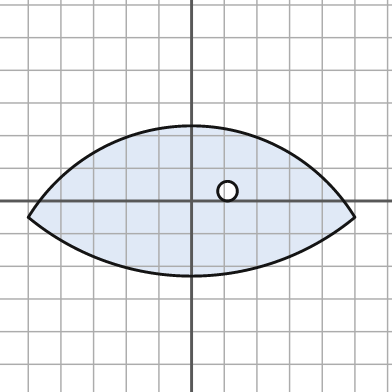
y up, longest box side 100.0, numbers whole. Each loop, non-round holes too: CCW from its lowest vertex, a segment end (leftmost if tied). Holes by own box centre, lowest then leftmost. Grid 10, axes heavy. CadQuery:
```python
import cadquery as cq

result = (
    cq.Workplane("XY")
    .moveTo(-50.0, -5.0)
    .threePointArc((0.0, -23.0), (50.0, -5.0))
    .threePointArc((0.0, 23.0), (-50.0, -5.0))
    .close()
    .moveTo(11.0, 3.0)
    .circle(3.0)
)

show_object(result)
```